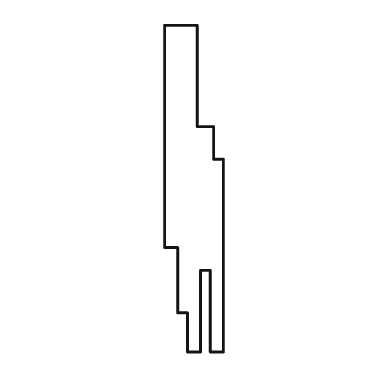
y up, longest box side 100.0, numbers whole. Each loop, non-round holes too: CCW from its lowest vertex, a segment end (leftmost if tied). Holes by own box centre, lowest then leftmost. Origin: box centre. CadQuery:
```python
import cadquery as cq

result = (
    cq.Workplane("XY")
    .moveTo(-2.0, -50.0)
    .lineTo(2.0, -50.0)
    .lineTo(2.0, -25.0)
    .lineTo(5.0, -25.0)
    .lineTo(5.0, -50.0)
    .lineTo(9.0, -50.0)
    .lineTo(9.0, 9.0)
    .lineTo(6.0, 9.0)
    .lineTo(6.0, 19.0)
    .lineTo(1.0, 19.0)
    .lineTo(1.0, 50.0)
    .lineTo(-9.0, 50.0)
    .lineTo(-9.0, -18.0)
    .lineTo(-5.0, -18.0)
    .lineTo(-5.0, -38.0)
    .lineTo(-2.0, -38.0)
    .close()
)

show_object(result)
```